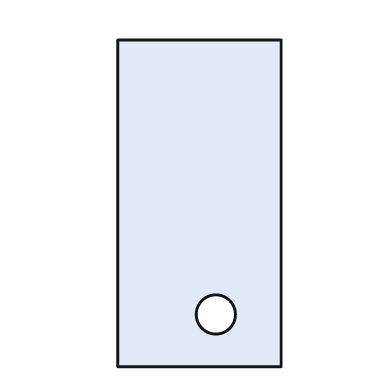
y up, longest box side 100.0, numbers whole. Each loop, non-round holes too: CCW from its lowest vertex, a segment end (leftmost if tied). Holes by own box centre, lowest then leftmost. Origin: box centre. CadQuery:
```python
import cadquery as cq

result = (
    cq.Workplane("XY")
    .moveTo(-25.0, -50.0)
    .lineTo(25.0, -50.0)
    .lineTo(25.0, 50.0)
    .lineTo(-25.0, 50.0)
    .close()
    .moveTo(5.0, -34.0)
    .circle(6.0)
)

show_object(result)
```